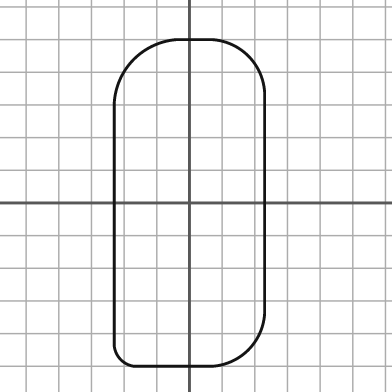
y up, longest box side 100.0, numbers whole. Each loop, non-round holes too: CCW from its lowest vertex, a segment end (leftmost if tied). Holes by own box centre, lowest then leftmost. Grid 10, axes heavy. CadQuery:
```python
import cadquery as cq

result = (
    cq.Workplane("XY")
    .moveTo(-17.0, -50.0)
    .lineTo(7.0, -50.0)
    .threePointArc((18.0, -45.0), (23.0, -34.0))
    .lineTo(23.0, 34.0)
    .threePointArc((18.0, 45.0), (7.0, 50.0))
    .lineTo(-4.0, 50.0)
    .threePointArc((-17.0, 44.0), (-23.0, 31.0))
    .lineTo(-23.0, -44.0)
    .threePointArc((-21.0, -48.0), (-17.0, -50.0))
    .close()
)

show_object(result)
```